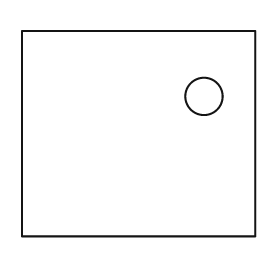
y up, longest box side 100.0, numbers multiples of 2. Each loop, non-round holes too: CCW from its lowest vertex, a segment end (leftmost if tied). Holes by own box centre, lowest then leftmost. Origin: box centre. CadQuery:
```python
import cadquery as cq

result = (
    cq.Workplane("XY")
    .moveTo(-50.0, -44.0)
    .lineTo(50.0, -44.0)
    .lineTo(50.0, 44.0)
    .lineTo(-50.0, 44.0)
    .close()
    .moveTo(28.0, 16.0)
    .circle(8.0)
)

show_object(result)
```